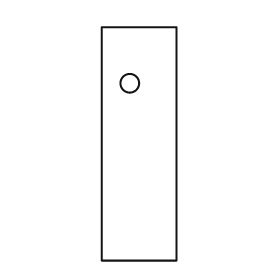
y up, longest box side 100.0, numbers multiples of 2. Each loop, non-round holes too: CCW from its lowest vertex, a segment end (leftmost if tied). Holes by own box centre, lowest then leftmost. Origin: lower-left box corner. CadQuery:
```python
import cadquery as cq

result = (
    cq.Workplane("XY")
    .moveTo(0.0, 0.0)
    .lineTo(32.0, 0.0)
    .lineTo(32.0, 100.0)
    .lineTo(0.0, 100.0)
    .close()
    .moveTo(12.0, 76.0)
    .circle(4.0)
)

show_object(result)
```